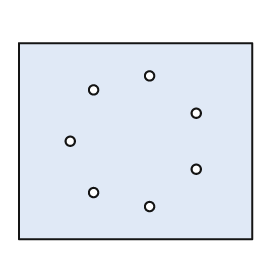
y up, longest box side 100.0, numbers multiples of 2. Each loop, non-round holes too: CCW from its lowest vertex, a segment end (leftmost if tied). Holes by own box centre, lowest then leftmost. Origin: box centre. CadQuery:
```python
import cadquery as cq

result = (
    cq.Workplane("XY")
    .moveTo(-50.0, -42.0)
    .lineTo(50.0, -42.0)
    .lineTo(50.0, 42.0)
    .lineTo(-50.0, 42.0)
    .close()
    .moveTo(6.0, -28.0)
    .circle(2.0)
    .moveTo(-18.0, -22.0)
    .circle(2.0)
    .moveTo(26.0, -12.0)
    .circle(2.0)
    .moveTo(-28.0, 0.0)
    .circle(2.0)
    .moveTo(26.0, 12.0)
    .circle(2.0)
    .moveTo(-18.0, 22.0)
    .circle(2.0)
    .moveTo(6.0, 28.0)
    .circle(2.0)
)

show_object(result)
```